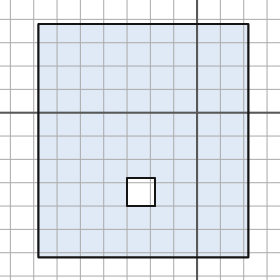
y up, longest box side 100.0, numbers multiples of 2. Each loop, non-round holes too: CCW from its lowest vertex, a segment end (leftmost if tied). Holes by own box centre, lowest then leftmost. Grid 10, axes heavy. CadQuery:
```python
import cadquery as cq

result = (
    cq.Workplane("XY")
    .moveTo(-68.0, -62.0)
    .lineTo(22.0, -62.0)
    .lineTo(22.0, 38.0)
    .lineTo(-68.0, 38.0)
    .close()
    .moveTo(-30.0, -40.0)
    .lineTo(-18.0, -40.0)
    .lineTo(-18.0, -28.0)
    .lineTo(-30.0, -28.0)
    .close()
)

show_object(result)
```